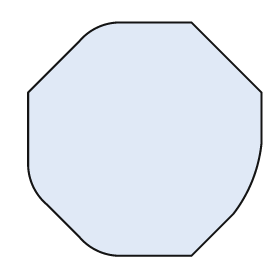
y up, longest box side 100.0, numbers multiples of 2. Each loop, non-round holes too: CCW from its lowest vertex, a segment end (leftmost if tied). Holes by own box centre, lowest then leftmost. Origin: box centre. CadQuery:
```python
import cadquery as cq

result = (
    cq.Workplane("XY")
    .moveTo(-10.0, -50.0)
    .lineTo(20.0, -50.0)
    .lineTo(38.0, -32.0)
    .threePointArc((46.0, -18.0), (50.0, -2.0))
    .lineTo(50.0, 20.0)
    .lineTo(20.0, 50.0)
    .lineTo(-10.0, 50.0)
    .threePointArc((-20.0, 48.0), (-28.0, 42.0))
    .lineTo(-50.0, 20.0)
    .lineTo(-50.0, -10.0)
    .threePointArc((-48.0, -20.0), (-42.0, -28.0))
    .lineTo(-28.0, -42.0)
    .threePointArc((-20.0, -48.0), (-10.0, -50.0))
    .close()
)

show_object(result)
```